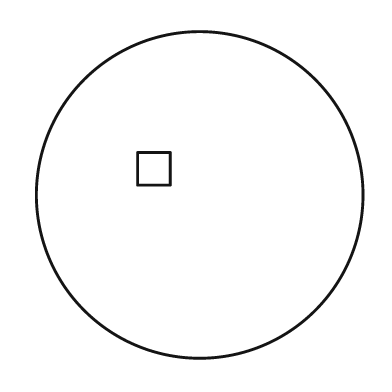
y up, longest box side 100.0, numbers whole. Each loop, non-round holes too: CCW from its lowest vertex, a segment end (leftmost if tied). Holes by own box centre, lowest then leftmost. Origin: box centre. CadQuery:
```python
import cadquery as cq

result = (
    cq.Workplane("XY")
    .moveTo(0.0, 0.0)
    .circle(50.0)
    .moveTo(-19.0, 3.0)
    .lineTo(-9.0, 3.0)
    .lineTo(-9.0, 13.0)
    .lineTo(-19.0, 13.0)
    .close()
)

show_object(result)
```